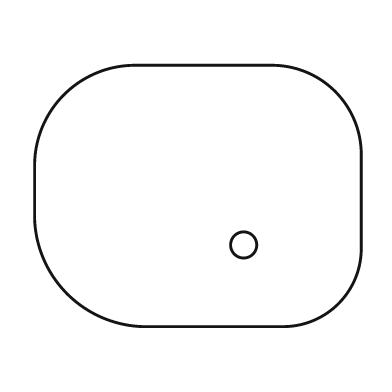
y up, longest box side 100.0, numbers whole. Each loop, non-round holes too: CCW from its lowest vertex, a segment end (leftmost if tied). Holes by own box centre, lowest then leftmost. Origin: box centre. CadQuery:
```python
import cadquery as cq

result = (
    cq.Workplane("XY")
    .moveTo(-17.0, -40.0)
    .lineTo(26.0, -40.0)
    .threePointArc((43.0, -33.0), (50.0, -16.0))
    .lineTo(50.0, 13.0)
    .threePointArc((42.0, 32.0), (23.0, 40.0))
    .lineTo(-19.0, 40.0)
    .threePointArc((-41.0, 31.0), (-50.0, 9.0))
    .lineTo(-50.0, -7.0)
    .threePointArc((-40.0, -30.0), (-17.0, -40.0))
    .close()
    .moveTo(14.0, -15.0)
    .circle(4.0)
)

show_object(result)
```